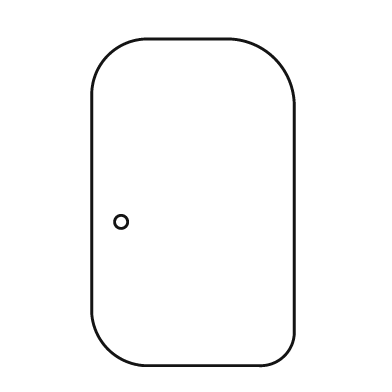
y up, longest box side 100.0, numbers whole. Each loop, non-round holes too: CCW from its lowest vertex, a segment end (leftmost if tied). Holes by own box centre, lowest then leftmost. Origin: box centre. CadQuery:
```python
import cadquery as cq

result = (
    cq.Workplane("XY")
    .moveTo(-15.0, -50.0)
    .lineTo(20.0, -50.0)
    .threePointArc((28.0, -47.0), (31.0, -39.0))
    .lineTo(31.0, 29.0)
    .threePointArc((25.0, 44.0), (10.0, 50.0))
    .lineTo(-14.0, 50.0)
    .threePointArc((-26.0, 45.0), (-31.0, 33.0))
    .lineTo(-31.0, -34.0)
    .threePointArc((-26.0, -45.0), (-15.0, -50.0))
    .close()
    .moveTo(-22.0, -6.0)
    .circle(2.0)
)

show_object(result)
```